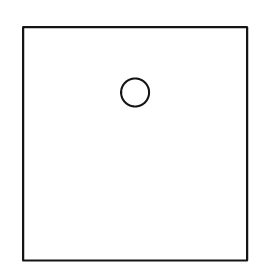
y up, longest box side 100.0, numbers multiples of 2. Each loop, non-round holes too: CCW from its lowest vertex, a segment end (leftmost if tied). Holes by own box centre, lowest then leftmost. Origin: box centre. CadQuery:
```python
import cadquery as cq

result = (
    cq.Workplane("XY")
    .moveTo(-48.0, -50.0)
    .lineTo(48.0, -50.0)
    .lineTo(48.0, 50.0)
    .lineTo(-48.0, 50.0)
    .close()
    .moveTo(0.0, 22.0)
    .circle(6.0)
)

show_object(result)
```